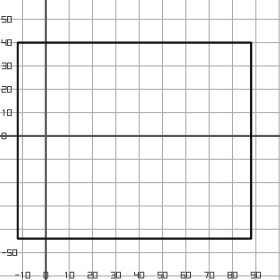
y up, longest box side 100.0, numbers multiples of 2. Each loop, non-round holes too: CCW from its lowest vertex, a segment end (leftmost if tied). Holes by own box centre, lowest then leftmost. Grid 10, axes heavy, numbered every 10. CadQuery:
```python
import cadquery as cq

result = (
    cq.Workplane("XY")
    .moveTo(-12.0, -44.0)
    .lineTo(88.0, -44.0)
    .lineTo(88.0, 40.0)
    .lineTo(-12.0, 40.0)
    .close()
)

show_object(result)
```